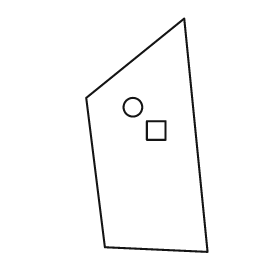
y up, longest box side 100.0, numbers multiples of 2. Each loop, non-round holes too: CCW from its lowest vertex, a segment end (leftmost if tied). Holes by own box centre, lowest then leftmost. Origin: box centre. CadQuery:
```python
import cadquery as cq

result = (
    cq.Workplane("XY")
    .moveTo(26.0, -50.0)
    .lineTo(16.0, 50.0)
    .lineTo(-26.0, 16.0)
    .lineTo(-18.0, -48.0)
    .close()
    .moveTo(0.0, -2.0)
    .lineTo(8.0, -2.0)
    .lineTo(8.0, 6.0)
    .lineTo(0.0, 6.0)
    .close()
    .moveTo(-6.0, 12.0)
    .circle(4.0)
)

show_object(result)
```